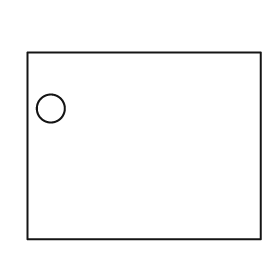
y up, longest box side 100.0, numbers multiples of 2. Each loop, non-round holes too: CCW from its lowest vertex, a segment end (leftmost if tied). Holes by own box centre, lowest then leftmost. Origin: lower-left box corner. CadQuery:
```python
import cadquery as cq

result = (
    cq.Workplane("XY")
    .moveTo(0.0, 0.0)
    .lineTo(100.0, 0.0)
    .lineTo(100.0, 80.0)
    .lineTo(0.0, 80.0)
    .close()
    .moveTo(10.0, 56.0)
    .circle(6.0)
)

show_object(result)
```